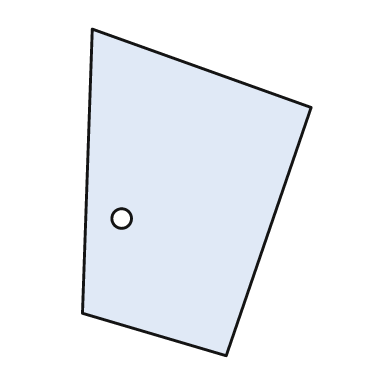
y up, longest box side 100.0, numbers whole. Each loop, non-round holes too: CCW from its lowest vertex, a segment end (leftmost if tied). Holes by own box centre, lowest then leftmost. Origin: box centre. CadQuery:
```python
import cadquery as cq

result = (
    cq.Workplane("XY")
    .moveTo(9.0, -50.0)
    .lineTo(35.0, 26.0)
    .lineTo(-32.0, 50.0)
    .lineTo(-35.0, -37.0)
    .close()
    .moveTo(-23.0, -8.0)
    .circle(3.0)
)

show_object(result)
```